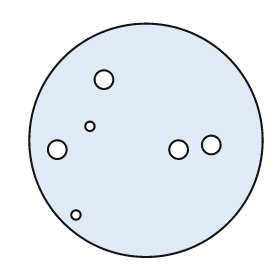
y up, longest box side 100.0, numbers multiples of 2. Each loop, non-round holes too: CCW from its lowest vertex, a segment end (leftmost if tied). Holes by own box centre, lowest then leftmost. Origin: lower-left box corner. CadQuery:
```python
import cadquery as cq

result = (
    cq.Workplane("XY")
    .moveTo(50.0, 50.0)
    .circle(50.0)
    .moveTo(20.0, 18.0)
    .circle(2.0)
    .moveTo(12.0, 46.0)
    .circle(4.0)
    .moveTo(64.0, 46.0)
    .circle(4.0)
    .moveTo(78.0, 48.0)
    .circle(4.0)
    .moveTo(26.0, 56.0)
    .circle(2.0)
    .moveTo(32.0, 76.0)
    .circle(4.0)
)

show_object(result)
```